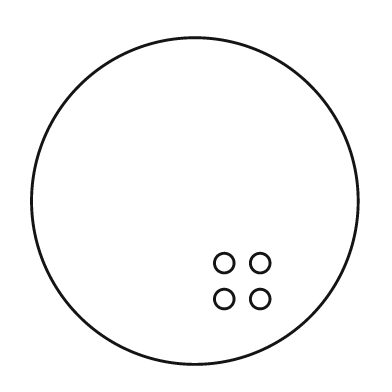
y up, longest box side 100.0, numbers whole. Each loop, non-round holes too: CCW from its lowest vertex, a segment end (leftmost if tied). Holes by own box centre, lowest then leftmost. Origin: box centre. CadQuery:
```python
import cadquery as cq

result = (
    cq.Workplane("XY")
    .moveTo(0.0, 0.0)
    .circle(50.0)
    .moveTo(9.0, -30.0)
    .circle(3.0)
    .moveTo(20.0, -30.0)
    .circle(3.0)
    .moveTo(9.0, -19.0)
    .circle(3.0)
    .moveTo(20.0, -19.0)
    .circle(3.0)
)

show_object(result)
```